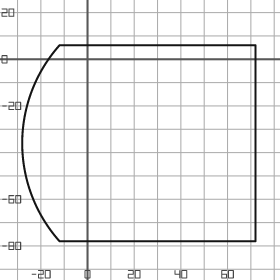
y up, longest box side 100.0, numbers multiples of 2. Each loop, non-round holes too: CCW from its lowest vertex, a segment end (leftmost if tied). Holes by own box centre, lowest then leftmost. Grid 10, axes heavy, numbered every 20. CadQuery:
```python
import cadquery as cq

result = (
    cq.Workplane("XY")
    .moveTo(-12.0, -78.0)
    .lineTo(72.0, -78.0)
    .lineTo(72.0, 6.0)
    .lineTo(-12.0, 6.0)
    .threePointArc((-28.0, -36.0), (-12.0, -78.0))
    .close()
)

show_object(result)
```